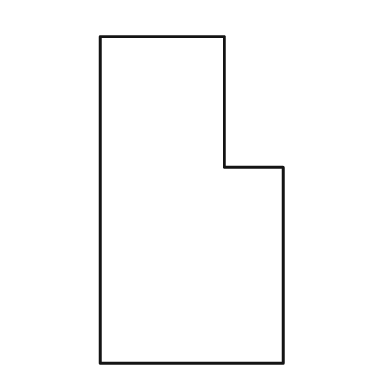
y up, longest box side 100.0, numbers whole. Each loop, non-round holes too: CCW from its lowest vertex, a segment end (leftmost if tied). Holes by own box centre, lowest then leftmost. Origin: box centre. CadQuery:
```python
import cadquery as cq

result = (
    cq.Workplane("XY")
    .moveTo(-28.0, -50.0)
    .lineTo(28.0, -50.0)
    .lineTo(28.0, 10.0)
    .lineTo(10.0, 10.0)
    .lineTo(10.0, 50.0)
    .lineTo(-28.0, 50.0)
    .close()
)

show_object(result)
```